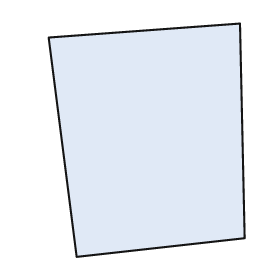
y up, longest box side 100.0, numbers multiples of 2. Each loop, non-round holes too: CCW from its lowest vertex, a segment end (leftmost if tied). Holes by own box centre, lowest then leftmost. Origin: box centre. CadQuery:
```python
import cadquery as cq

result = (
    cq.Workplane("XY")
    .moveTo(-30.0, -50.0)
    .lineTo(42.0, -42.0)
    .lineTo(40.0, 50.0)
    .lineTo(-42.0, 44.0)
    .close()
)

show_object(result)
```